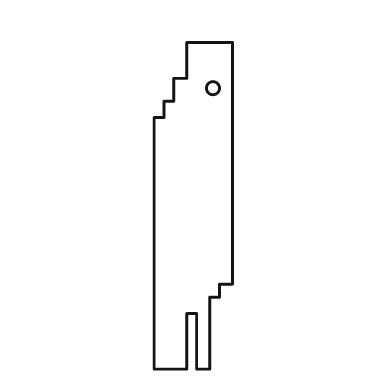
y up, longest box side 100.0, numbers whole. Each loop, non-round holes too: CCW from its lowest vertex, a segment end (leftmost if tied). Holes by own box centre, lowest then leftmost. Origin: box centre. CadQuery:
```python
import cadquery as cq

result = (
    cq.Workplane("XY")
    .moveTo(-12.0, -50.0)
    .lineTo(-2.0, -50.0)
    .lineTo(-2.0, -33.0)
    .lineTo(1.0, -33.0)
    .lineTo(1.0, -50.0)
    .lineTo(5.0, -50.0)
    .lineTo(5.0, -28.0)
    .lineTo(8.0, -28.0)
    .lineTo(8.0, -24.0)
    .lineTo(12.0, -24.0)
    .lineTo(12.0, 50.0)
    .lineTo(-2.0, 50.0)
    .lineTo(-2.0, 39.0)
    .lineTo(-6.0, 39.0)
    .lineTo(-6.0, 32.0)
    .lineTo(-9.0, 32.0)
    .lineTo(-9.0, 27.0)
    .lineTo(-12.0, 27.0)
    .close()
    .moveTo(6.0, 36.0)
    .circle(2.0)
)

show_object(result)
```